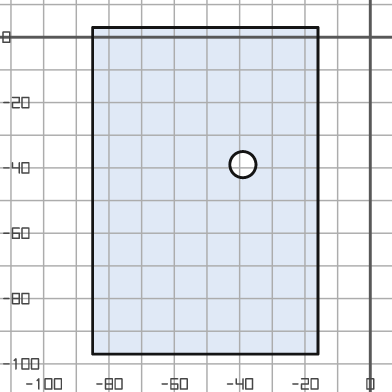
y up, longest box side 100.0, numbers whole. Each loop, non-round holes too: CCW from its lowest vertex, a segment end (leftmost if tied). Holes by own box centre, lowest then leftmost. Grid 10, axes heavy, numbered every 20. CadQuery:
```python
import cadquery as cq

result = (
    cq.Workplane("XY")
    .moveTo(-85.0, -97.0)
    .lineTo(-16.0, -97.0)
    .lineTo(-16.0, 3.0)
    .lineTo(-85.0, 3.0)
    .close()
    .moveTo(-39.0, -39.0)
    .circle(4.0)
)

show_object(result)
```